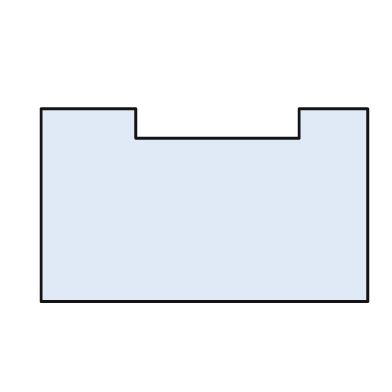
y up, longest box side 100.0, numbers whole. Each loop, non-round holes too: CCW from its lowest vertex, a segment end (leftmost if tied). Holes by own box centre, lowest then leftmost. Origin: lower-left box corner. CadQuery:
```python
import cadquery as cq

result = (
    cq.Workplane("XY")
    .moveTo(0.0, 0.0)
    .lineTo(100.0, 0.0)
    .lineTo(100.0, 59.0)
    .lineTo(79.0, 59.0)
    .lineTo(79.0, 50.0)
    .lineTo(29.0, 50.0)
    .lineTo(29.0, 59.0)
    .lineTo(0.0, 59.0)
    .close()
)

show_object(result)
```